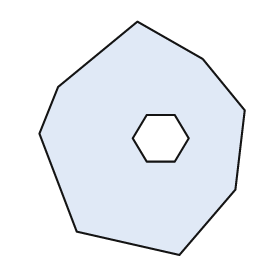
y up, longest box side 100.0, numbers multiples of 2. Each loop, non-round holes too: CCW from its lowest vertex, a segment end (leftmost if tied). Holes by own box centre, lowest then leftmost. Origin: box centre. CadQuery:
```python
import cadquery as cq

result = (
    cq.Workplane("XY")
    .moveTo(16.0, -50.0)
    .lineTo(40.0, -22.0)
    .lineTo(44.0, 12.0)
    .lineTo(26.0, 34.0)
    .lineTo(-2.0, 50.0)
    .lineTo(-36.0, 22.0)
    .lineTo(-44.0, 2.0)
    .lineTo(-28.0, -40.0)
    .close()
    .moveTo(2.0, -10.0)
    .lineTo(14.0, -10.0)
    .lineTo(20.0, 0.0)
    .lineTo(14.0, 10.0)
    .lineTo(2.0, 10.0)
    .lineTo(-4.0, 0.0)
    .close()
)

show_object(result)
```